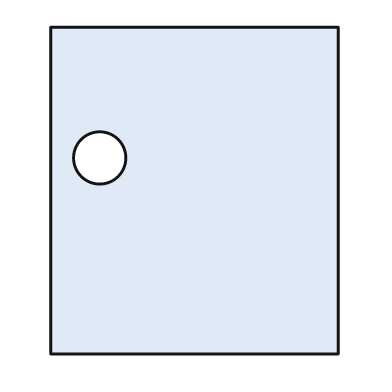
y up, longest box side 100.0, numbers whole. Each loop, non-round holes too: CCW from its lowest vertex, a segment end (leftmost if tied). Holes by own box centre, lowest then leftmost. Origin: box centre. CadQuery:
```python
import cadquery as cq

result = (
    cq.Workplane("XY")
    .moveTo(-44.0, -50.0)
    .lineTo(44.0, -50.0)
    .lineTo(44.0, 50.0)
    .lineTo(-44.0, 50.0)
    .close()
    .moveTo(-29.0, 10.0)
    .circle(8.0)
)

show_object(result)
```